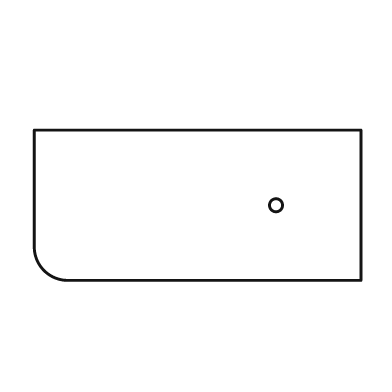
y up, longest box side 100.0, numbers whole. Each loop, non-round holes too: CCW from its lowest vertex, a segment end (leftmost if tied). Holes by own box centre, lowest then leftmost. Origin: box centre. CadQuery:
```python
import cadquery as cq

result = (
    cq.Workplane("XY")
    .moveTo(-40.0, -23.0)
    .lineTo(50.0, -23.0)
    .lineTo(50.0, 23.0)
    .lineTo(-50.0, 23.0)
    .lineTo(-50.0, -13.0)
    .threePointArc((-47.0, -20.0), (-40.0, -23.0))
    .close()
    .moveTo(24.0, 0.0)
    .circle(2.0)
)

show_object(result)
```